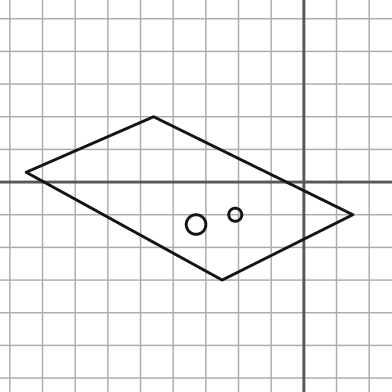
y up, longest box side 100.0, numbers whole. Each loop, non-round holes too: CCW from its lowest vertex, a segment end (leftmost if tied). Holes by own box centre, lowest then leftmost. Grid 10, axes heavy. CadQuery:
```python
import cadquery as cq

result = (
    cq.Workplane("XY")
    .moveTo(-25.0, -30.0)
    .lineTo(15.0, -10.0)
    .lineTo(-46.0, 20.0)
    .lineTo(-85.0, 3.0)
    .close()
    .moveTo(-33.0, -13.0)
    .circle(3.0)
    .moveTo(-21.0, -10.0)
    .circle(2.0)
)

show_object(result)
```